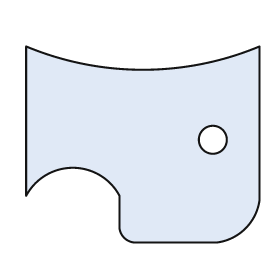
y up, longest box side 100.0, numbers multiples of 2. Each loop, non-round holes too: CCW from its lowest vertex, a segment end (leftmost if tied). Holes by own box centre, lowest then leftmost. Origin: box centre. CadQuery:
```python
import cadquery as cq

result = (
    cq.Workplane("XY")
    .moveTo(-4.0, -42.0)
    .lineTo(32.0, -42.0)
    .threePointArc((44.0, -36.0), (50.0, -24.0))
    .lineTo(50.0, 42.0)
    .threePointArc((0.0, 32.0), (-50.0, 42.0))
    .lineTo(-50.0, -22.0)
    .threePointArc((-30.0, -10.0), (-10.0, -22.0))
    .lineTo(-10.0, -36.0)
    .threePointArc((-8.0, -40.0), (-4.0, -42.0))
    .close()
    .moveTo(30.0, 2.0)
    .circle(6.0)
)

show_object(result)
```